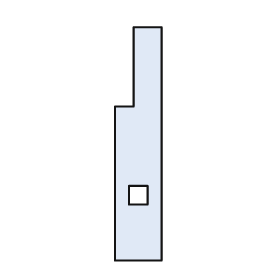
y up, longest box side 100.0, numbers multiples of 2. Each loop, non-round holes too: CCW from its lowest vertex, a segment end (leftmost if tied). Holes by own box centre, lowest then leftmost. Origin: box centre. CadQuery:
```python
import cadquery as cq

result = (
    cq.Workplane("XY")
    .moveTo(-10.0, -50.0)
    .lineTo(10.0, -50.0)
    .lineTo(10.0, 50.0)
    .lineTo(-2.0, 50.0)
    .lineTo(-2.0, 16.0)
    .lineTo(-10.0, 16.0)
    .close()
    .moveTo(-4.0, -26.0)
    .lineTo(4.0, -26.0)
    .lineTo(4.0, -18.0)
    .lineTo(-4.0, -18.0)
    .close()
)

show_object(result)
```